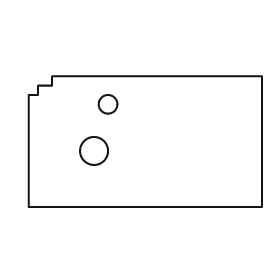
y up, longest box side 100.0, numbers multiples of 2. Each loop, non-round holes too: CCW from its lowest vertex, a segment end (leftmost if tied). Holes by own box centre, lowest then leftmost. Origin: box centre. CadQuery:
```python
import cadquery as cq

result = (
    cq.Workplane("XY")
    .moveTo(-50.0, -28.0)
    .lineTo(50.0, -28.0)
    .lineTo(50.0, 28.0)
    .lineTo(-40.0, 28.0)
    .lineTo(-40.0, 24.0)
    .lineTo(-46.0, 24.0)
    .lineTo(-46.0, 20.0)
    .lineTo(-50.0, 20.0)
    .close()
    .moveTo(-22.0, -4.0)
    .circle(6.0)
    .moveTo(-16.0, 16.0)
    .circle(4.0)
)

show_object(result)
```